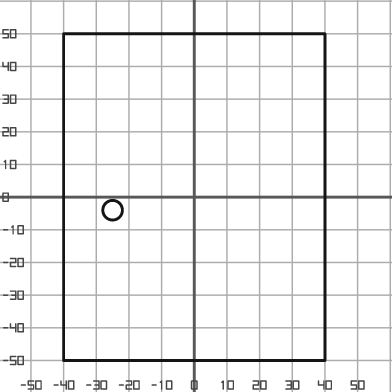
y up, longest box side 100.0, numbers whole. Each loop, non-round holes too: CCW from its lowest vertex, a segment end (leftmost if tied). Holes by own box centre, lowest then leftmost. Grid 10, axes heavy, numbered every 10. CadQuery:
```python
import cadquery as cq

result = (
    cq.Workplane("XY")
    .moveTo(-40.0, -50.0)
    .lineTo(40.0, -50.0)
    .lineTo(40.0, 50.0)
    .lineTo(-40.0, 50.0)
    .close()
    .moveTo(-25.0, -4.0)
    .circle(3.0)
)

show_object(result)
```